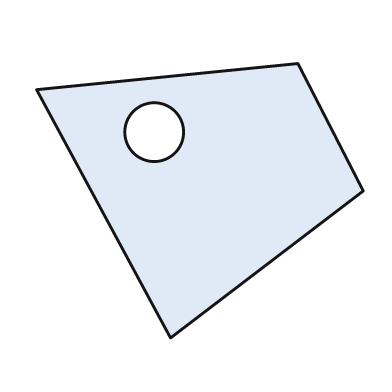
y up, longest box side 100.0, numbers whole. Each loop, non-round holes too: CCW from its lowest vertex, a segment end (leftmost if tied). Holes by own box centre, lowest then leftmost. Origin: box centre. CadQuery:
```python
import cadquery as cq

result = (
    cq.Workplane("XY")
    .moveTo(-9.0, -42.0)
    .lineTo(50.0, 3.0)
    .lineTo(30.0, 42.0)
    .lineTo(-50.0, 34.0)
    .close()
    .moveTo(-14.0, 21.0)
    .circle(9.0)
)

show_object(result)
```